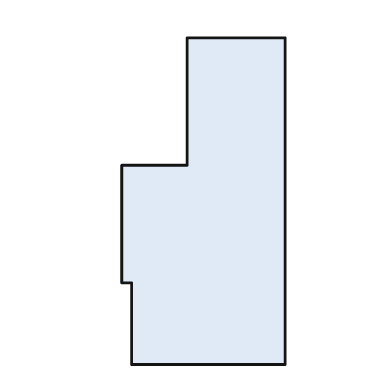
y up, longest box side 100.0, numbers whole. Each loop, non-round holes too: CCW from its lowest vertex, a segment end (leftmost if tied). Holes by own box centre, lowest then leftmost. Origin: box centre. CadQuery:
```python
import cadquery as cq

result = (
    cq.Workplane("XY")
    .moveTo(-22.0, -50.0)
    .lineTo(25.0, -50.0)
    .lineTo(25.0, 50.0)
    .lineTo(-5.0, 50.0)
    .lineTo(-5.0, 11.0)
    .lineTo(-25.0, 11.0)
    .lineTo(-25.0, -25.0)
    .lineTo(-22.0, -25.0)
    .close()
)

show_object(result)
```